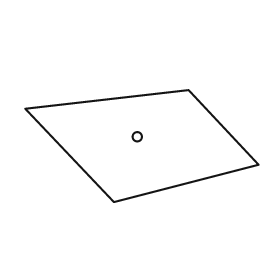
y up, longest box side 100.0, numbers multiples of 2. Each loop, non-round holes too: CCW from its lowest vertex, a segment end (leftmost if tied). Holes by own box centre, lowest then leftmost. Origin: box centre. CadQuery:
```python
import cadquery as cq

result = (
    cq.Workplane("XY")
    .moveTo(-12.0, -24.0)
    .lineTo(50.0, -8.0)
    .lineTo(20.0, 24.0)
    .lineTo(-50.0, 16.0)
    .close()
    .moveTo(-2.0, 4.0)
    .circle(2.0)
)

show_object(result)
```